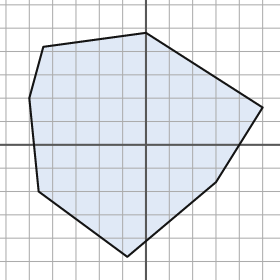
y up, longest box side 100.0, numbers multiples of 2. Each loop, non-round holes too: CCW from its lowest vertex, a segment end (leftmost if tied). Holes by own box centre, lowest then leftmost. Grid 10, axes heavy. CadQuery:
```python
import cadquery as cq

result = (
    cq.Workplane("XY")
    .moveTo(-8.0, -48.0)
    .lineTo(30.0, -16.0)
    .lineTo(50.0, 16.0)
    .lineTo(0.0, 48.0)
    .lineTo(-44.0, 42.0)
    .lineTo(-50.0, 20.0)
    .lineTo(-46.0, -20.0)
    .close()
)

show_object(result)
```